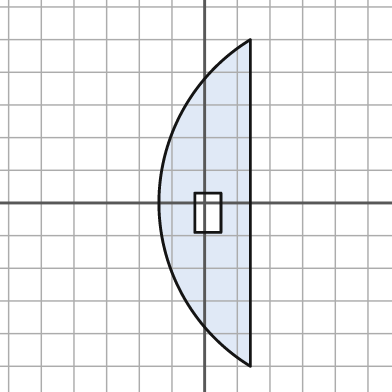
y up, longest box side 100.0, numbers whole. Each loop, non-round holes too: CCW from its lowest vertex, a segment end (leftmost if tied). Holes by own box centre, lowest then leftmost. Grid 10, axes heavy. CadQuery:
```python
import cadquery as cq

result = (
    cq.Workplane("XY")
    .moveTo(14.0, -50.0)
    .lineTo(14.0, 50.0)
    .threePointArc((-14.0, 0.0), (14.0, -50.0))
    .close()
    .moveTo(-3.0, -9.0)
    .lineTo(5.0, -9.0)
    .lineTo(5.0, 3.0)
    .lineTo(-3.0, 3.0)
    .close()
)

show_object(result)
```